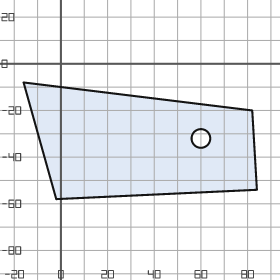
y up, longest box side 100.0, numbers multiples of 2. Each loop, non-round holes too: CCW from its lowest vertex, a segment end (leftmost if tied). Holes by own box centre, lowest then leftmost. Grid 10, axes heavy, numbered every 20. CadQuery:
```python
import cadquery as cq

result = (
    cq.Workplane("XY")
    .moveTo(-2.0, -58.0)
    .lineTo(84.0, -54.0)
    .lineTo(82.0, -20.0)
    .lineTo(-16.0, -8.0)
    .close()
    .moveTo(60.0, -32.0)
    .circle(4.0)
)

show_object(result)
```